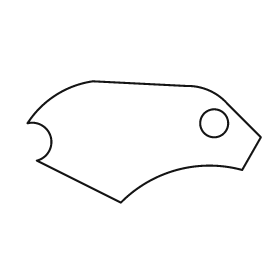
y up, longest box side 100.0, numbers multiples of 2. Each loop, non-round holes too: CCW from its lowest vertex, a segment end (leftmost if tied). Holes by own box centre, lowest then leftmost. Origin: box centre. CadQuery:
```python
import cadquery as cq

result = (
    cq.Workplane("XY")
    .moveTo(-10.0, -26.0)
    .threePointArc((14.0, -12.0), (42.0, -12.0))
    .lineTo(50.0, 2.0)
    .lineTo(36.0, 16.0)
    .threePointArc((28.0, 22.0), (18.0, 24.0))
    .lineTo(-22.0, 26.0)
    .threePointArc((-38.0, 20.0), (-50.0, 8.0))
    .threePointArc((-40.0, 2.0), (-46.0, -8.0))
    .close()
    .moveTo(30.0, 8.0)
    .circle(6.0)
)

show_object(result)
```